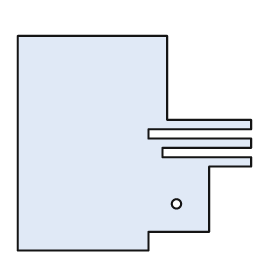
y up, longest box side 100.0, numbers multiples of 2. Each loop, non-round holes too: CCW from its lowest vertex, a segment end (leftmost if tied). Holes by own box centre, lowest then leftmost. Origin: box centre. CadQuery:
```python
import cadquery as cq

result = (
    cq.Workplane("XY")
    .moveTo(-50.0, -46.0)
    .lineTo(6.0, -46.0)
    .lineTo(6.0, -38.0)
    .lineTo(32.0, -38.0)
    .lineTo(32.0, -10.0)
    .lineTo(50.0, -10.0)
    .lineTo(50.0, -6.0)
    .lineTo(12.0, -6.0)
    .lineTo(12.0, -2.0)
    .lineTo(50.0, -2.0)
    .lineTo(50.0, 2.0)
    .lineTo(6.0, 2.0)
    .lineTo(6.0, 6.0)
    .lineTo(50.0, 6.0)
    .lineTo(50.0, 10.0)
    .lineTo(14.0, 10.0)
    .lineTo(14.0, 46.0)
    .lineTo(-50.0, 46.0)
    .close()
    .moveTo(18.0, -26.0)
    .circle(2.0)
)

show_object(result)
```